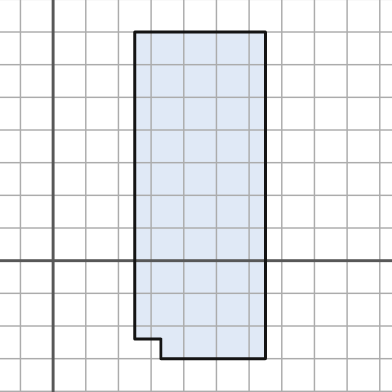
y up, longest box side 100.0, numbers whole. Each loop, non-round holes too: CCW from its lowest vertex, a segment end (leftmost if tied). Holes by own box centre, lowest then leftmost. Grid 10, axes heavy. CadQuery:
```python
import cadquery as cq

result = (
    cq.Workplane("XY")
    .moveTo(33.0, -30.0)
    .lineTo(65.0, -30.0)
    .lineTo(65.0, 70.0)
    .lineTo(25.0, 70.0)
    .lineTo(25.0, -24.0)
    .lineTo(33.0, -24.0)
    .close()
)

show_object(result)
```